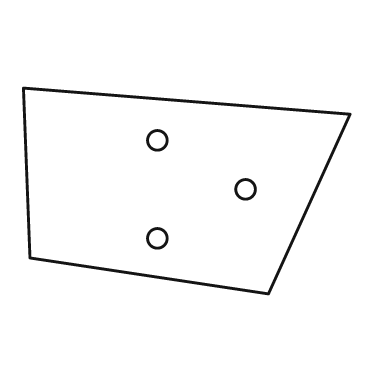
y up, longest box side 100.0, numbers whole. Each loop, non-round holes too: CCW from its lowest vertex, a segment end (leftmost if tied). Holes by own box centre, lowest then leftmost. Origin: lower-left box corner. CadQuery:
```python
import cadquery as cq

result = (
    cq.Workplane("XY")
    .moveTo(75.0, 0.0)
    .lineTo(100.0, 55.0)
    .lineTo(0.0, 63.0)
    .lineTo(2.0, 11.0)
    .close()
    .moveTo(41.0, 17.0)
    .circle(3.0)
    .moveTo(68.0, 32.0)
    .circle(3.0)
    .moveTo(41.0, 47.0)
    .circle(3.0)
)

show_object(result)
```